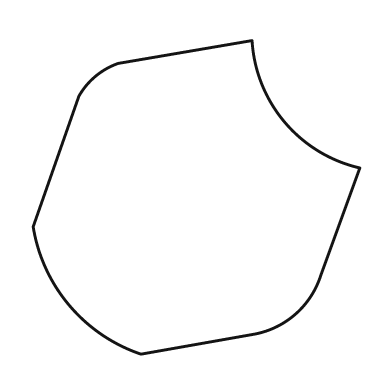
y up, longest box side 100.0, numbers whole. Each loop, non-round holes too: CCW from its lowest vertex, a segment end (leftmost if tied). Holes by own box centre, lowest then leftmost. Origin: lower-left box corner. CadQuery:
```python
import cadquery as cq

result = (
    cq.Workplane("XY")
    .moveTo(33.0, 0.0)
    .lineTo(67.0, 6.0)
    .threePointArc((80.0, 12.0), (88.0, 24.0))
    .lineTo(100.0, 57.0)
    .threePointArc((77.0, 71.0), (67.0, 96.0))
    .lineTo(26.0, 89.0)
    .threePointArc((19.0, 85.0), (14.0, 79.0))
    .lineTo(0.0, 39.0)
    .threePointArc((11.0, 15.0), (33.0, 0.0))
    .close()
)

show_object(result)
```